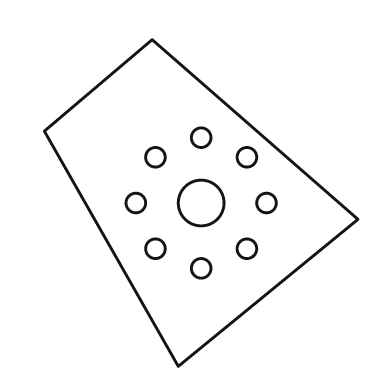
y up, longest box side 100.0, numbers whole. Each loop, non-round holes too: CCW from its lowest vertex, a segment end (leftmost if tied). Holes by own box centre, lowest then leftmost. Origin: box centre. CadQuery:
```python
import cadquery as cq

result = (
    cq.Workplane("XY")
    .moveTo(-7.0, -50.0)
    .lineTo(48.0, -5.0)
    .lineTo(-15.0, 50.0)
    .lineTo(-48.0, 22.0)
    .close()
    .moveTo(0.0, -20.0)
    .circle(3.0)
    .moveTo(-14.0, -14.0)
    .circle(3.0)
    .moveTo(14.0, -14.0)
    .circle(3.0)
    .moveTo(-20.0, 0.0)
    .circle(3.0)
    .moveTo(0.0, 0.0)
    .circle(7.0)
    .moveTo(20.0, 0.0)
    .circle(3.0)
    .moveTo(-14.0, 14.0)
    .circle(3.0)
    .moveTo(14.0, 14.0)
    .circle(3.0)
    .moveTo(0.0, 20.0)
    .circle(3.0)
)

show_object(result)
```